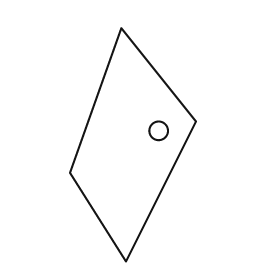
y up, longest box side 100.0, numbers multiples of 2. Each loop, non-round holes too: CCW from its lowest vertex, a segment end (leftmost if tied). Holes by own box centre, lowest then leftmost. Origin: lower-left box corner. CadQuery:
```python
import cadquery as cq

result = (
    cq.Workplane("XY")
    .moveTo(24.0, 0.0)
    .lineTo(54.0, 60.0)
    .lineTo(22.0, 100.0)
    .lineTo(0.0, 38.0)
    .close()
    .moveTo(38.0, 56.0)
    .circle(4.0)
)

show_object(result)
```